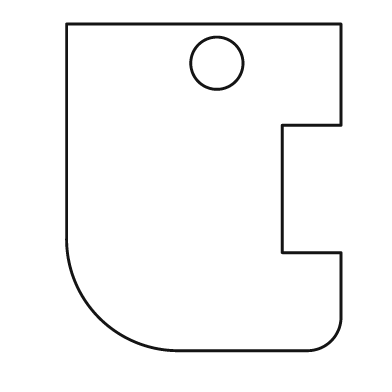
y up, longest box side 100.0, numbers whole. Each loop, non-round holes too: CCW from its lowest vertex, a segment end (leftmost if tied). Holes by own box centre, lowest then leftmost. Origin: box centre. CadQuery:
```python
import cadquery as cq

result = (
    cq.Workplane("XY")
    .moveTo(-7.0, -50.0)
    .lineTo(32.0, -50.0)
    .threePointArc((39.0, -47.0), (42.0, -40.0))
    .lineTo(42.0, -20.0)
    .lineTo(24.0, -20.0)
    .lineTo(24.0, 19.0)
    .lineTo(42.0, 19.0)
    .lineTo(42.0, 50.0)
    .lineTo(-42.0, 50.0)
    .lineTo(-42.0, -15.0)
    .threePointArc((-32.0, -40.0), (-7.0, -50.0))
    .close()
    .moveTo(4.0, 38.0)
    .circle(8.0)
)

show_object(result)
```